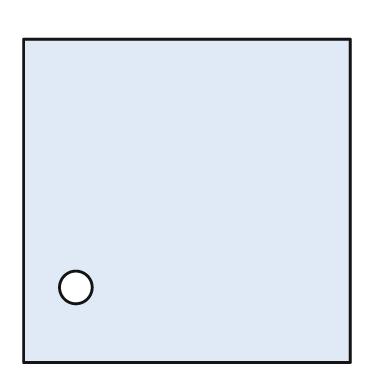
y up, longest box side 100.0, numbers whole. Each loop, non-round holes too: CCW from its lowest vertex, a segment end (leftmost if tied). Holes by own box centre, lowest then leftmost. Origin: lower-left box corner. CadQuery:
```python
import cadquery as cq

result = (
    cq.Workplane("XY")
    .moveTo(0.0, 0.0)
    .lineTo(100.0, 0.0)
    .lineTo(100.0, 99.0)
    .lineTo(0.0, 99.0)
    .close()
    .moveTo(16.0, 23.0)
    .circle(5.0)
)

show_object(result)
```